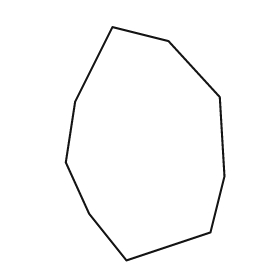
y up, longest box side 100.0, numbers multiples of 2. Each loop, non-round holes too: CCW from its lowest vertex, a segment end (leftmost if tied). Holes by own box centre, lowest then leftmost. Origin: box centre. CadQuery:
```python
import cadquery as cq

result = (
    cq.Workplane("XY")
    .moveTo(-8.0, -50.0)
    .lineTo(28.0, -38.0)
    .lineTo(34.0, -14.0)
    .lineTo(32.0, 20.0)
    .lineTo(10.0, 44.0)
    .lineTo(-14.0, 50.0)
    .lineTo(-30.0, 18.0)
    .lineTo(-34.0, -8.0)
    .lineTo(-24.0, -30.0)
    .close()
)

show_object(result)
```